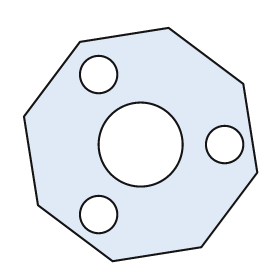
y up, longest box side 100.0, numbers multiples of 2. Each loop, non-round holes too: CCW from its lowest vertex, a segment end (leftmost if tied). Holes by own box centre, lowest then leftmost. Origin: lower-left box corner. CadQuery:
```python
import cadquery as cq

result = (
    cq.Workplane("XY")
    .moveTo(38.0, 0.0)
    .lineTo(76.0, 6.0)
    .lineTo(100.0, 38.0)
    .lineTo(94.0, 76.0)
    .lineTo(62.0, 100.0)
    .lineTo(24.0, 94.0)
    .lineTo(0.0, 62.0)
    .lineTo(6.0, 24.0)
    .close()
    .moveTo(32.0, 20.0)
    .circle(8.0)
    .moveTo(50.0, 50.0)
    .circle(18.0)
    .moveTo(86.0, 50.0)
    .circle(8.0)
    .moveTo(32.0, 80.0)
    .circle(8.0)
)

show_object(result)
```